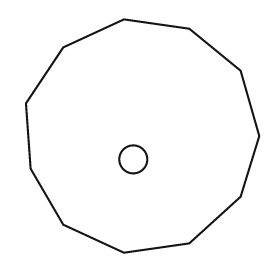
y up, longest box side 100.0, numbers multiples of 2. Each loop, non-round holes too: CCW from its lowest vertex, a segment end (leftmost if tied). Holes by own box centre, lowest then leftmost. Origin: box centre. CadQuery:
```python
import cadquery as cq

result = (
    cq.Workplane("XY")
    .moveTo(-8.0, -50.0)
    .lineTo(20.0, -46.0)
    .lineTo(42.0, -26.0)
    .lineTo(50.0, 0.0)
    .lineTo(42.0, 28.0)
    .lineTo(20.0, 46.0)
    .lineTo(-8.0, 50.0)
    .lineTo(-34.0, 38.0)
    .lineTo(-50.0, 14.0)
    .lineTo(-48.0, -14.0)
    .lineTo(-34.0, -38.0)
    .close()
    .moveTo(-4.0, -10.0)
    .circle(6.0)
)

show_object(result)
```